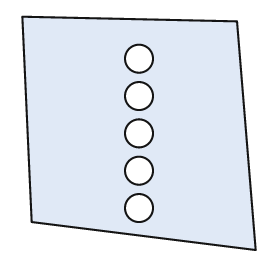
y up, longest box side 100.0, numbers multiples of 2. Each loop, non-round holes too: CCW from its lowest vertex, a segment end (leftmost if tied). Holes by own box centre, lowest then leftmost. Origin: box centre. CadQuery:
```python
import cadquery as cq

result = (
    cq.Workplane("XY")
    .moveTo(50.0, -50.0)
    .lineTo(42.0, 48.0)
    .lineTo(-50.0, 50.0)
    .lineTo(-46.0, -38.0)
    .close()
    .moveTo(0.0, -32.0)
    .circle(6.0)
    .moveTo(0.0, -16.0)
    .circle(6.0)
    .moveTo(0.0, 0.0)
    .circle(6.0)
    .moveTo(0.0, 16.0)
    .circle(6.0)
    .moveTo(0.0, 32.0)
    .circle(6.0)
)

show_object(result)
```